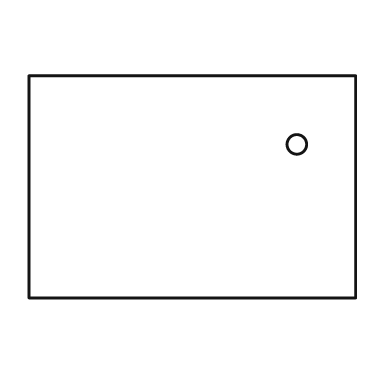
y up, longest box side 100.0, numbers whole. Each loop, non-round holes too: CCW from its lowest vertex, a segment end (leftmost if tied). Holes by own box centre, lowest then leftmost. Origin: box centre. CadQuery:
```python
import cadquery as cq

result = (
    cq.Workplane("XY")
    .moveTo(-50.0, -34.0)
    .lineTo(50.0, -34.0)
    .lineTo(50.0, 34.0)
    .lineTo(-50.0, 34.0)
    .close()
    .moveTo(32.0, 13.0)
    .circle(3.0)
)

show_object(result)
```